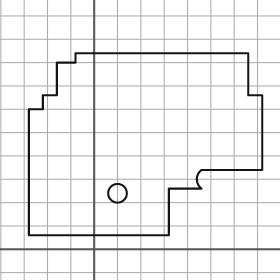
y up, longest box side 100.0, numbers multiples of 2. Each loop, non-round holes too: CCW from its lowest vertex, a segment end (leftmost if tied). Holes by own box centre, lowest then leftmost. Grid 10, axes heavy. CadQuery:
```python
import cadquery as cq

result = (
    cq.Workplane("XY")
    .moveTo(-28.0, 6.0)
    .lineTo(32.0, 6.0)
    .lineTo(32.0, 26.0)
    .lineTo(46.0, 26.0)
    .threePointArc((44.0, 30.0), (46.0, 34.0))
    .lineTo(72.0, 34.0)
    .lineTo(72.0, 66.0)
    .lineTo(66.0, 66.0)
    .lineTo(66.0, 84.0)
    .lineTo(-8.0, 84.0)
    .lineTo(-8.0, 80.0)
    .lineTo(-16.0, 80.0)
    .lineTo(-16.0, 66.0)
    .lineTo(-22.0, 66.0)
    .lineTo(-22.0, 60.0)
    .lineTo(-28.0, 60.0)
    .close()
    .moveTo(10.0, 24.0)
    .circle(4.0)
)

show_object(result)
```